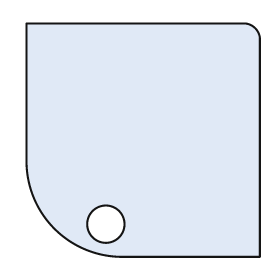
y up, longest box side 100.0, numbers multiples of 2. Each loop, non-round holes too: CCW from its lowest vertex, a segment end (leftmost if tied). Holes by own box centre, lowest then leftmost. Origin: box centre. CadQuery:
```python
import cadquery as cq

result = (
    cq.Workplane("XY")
    .moveTo(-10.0, -50.0)
    .lineTo(50.0, -50.0)
    .lineTo(50.0, 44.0)
    .threePointArc((48.0, 48.0), (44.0, 50.0))
    .lineTo(-50.0, 50.0)
    .lineTo(-50.0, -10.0)
    .threePointArc((-38.0, -38.0), (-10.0, -50.0))
    .close()
    .moveTo(-16.0, -36.0)
    .circle(8.0)
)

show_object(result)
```